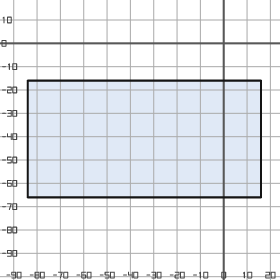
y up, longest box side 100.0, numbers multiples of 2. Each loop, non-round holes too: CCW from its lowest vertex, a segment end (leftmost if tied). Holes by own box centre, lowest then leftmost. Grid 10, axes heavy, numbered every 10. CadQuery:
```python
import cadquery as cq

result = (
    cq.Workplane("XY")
    .moveTo(-84.0, -66.0)
    .lineTo(16.0, -66.0)
    .lineTo(16.0, -16.0)
    .lineTo(-84.0, -16.0)
    .close()
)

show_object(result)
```